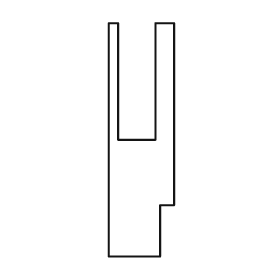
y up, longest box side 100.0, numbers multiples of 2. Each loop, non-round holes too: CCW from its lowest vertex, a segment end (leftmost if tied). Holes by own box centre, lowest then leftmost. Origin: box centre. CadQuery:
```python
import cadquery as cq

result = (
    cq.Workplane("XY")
    .moveTo(-14.0, -50.0)
    .lineTo(8.0, -50.0)
    .lineTo(8.0, -28.0)
    .lineTo(14.0, -28.0)
    .lineTo(14.0, 50.0)
    .lineTo(6.0, 50.0)
    .lineTo(6.0, 0.0)
    .lineTo(-10.0, 0.0)
    .lineTo(-10.0, 50.0)
    .lineTo(-14.0, 50.0)
    .close()
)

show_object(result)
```